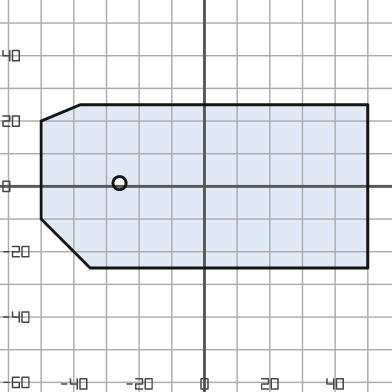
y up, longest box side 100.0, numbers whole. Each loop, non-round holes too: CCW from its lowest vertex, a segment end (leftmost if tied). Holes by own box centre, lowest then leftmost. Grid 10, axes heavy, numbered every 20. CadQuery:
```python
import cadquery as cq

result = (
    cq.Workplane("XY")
    .moveTo(-35.0, -25.0)
    .lineTo(50.0, -25.0)
    .lineTo(50.0, 25.0)
    .lineTo(-38.0, 25.0)
    .lineTo(-50.0, 20.0)
    .lineTo(-50.0, -10.0)
    .close()
    .moveTo(-26.0, 1.0)
    .circle(2.0)
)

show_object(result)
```